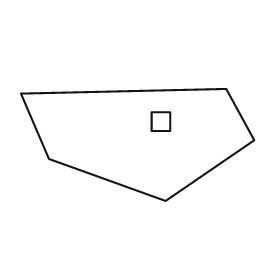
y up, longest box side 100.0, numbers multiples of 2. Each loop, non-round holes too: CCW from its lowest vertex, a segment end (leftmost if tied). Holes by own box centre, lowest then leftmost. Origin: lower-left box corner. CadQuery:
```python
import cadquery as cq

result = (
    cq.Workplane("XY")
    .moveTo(62.0, 0.0)
    .lineTo(100.0, 26.0)
    .lineTo(88.0, 48.0)
    .lineTo(0.0, 46.0)
    .lineTo(12.0, 18.0)
    .close()
    .moveTo(56.0, 30.0)
    .lineTo(64.0, 30.0)
    .lineTo(64.0, 38.0)
    .lineTo(56.0, 38.0)
    .close()
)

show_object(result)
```